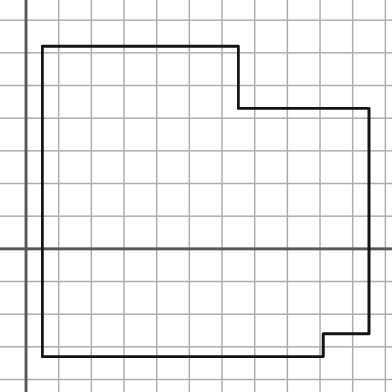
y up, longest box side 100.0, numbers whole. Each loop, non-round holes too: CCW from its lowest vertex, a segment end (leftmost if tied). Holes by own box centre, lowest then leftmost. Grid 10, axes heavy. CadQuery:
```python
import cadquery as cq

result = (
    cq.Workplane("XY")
    .moveTo(5.0, -33.0)
    .lineTo(91.0, -33.0)
    .lineTo(91.0, -26.0)
    .lineTo(105.0, -26.0)
    .lineTo(105.0, 43.0)
    .lineTo(65.0, 43.0)
    .lineTo(65.0, 62.0)
    .lineTo(5.0, 62.0)
    .close()
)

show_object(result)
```